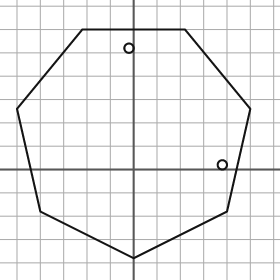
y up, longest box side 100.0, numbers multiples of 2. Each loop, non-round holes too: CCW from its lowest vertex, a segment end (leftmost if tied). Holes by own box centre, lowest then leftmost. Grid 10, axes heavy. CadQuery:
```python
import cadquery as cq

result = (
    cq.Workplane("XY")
    .moveTo(0.0, -38.0)
    .lineTo(40.0, -18.0)
    .lineTo(50.0, 26.0)
    .lineTo(22.0, 60.0)
    .lineTo(-22.0, 60.0)
    .lineTo(-50.0, 26.0)
    .lineTo(-40.0, -18.0)
    .close()
    .moveTo(38.0, 2.0)
    .circle(2.0)
    .moveTo(-2.0, 52.0)
    .circle(2.0)
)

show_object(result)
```